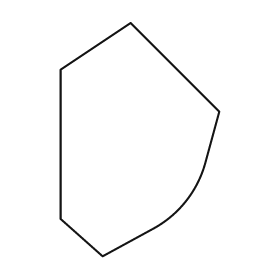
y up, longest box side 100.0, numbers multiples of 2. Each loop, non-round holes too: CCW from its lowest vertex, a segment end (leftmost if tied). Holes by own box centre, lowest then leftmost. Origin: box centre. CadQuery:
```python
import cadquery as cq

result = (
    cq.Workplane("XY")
    .moveTo(-16.0, -50.0)
    .lineTo(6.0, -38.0)
    .threePointArc((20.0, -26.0), (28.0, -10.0))
    .lineTo(34.0, 12.0)
    .lineTo(-4.0, 50.0)
    .lineTo(-34.0, 30.0)
    .lineTo(-34.0, -34.0)
    .close()
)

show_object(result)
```